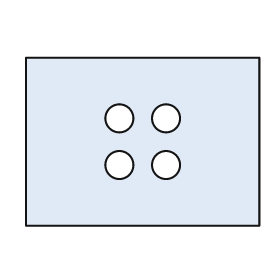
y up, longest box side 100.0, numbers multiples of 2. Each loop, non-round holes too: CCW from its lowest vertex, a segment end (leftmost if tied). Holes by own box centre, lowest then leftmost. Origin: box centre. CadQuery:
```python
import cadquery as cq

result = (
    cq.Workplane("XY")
    .moveTo(-50.0, -36.0)
    .lineTo(50.0, -36.0)
    .lineTo(50.0, 36.0)
    .lineTo(-50.0, 36.0)
    .close()
    .moveTo(-10.0, -10.0)
    .circle(6.0)
    .moveTo(10.0, -10.0)
    .circle(6.0)
    .moveTo(-10.0, 10.0)
    .circle(6.0)
    .moveTo(10.0, 10.0)
    .circle(6.0)
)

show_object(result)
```